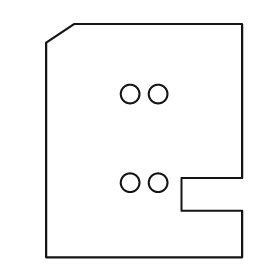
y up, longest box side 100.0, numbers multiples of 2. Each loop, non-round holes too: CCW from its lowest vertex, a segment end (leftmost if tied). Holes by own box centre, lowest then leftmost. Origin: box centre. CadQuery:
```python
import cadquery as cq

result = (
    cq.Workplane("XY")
    .moveTo(-42.0, -50.0)
    .lineTo(42.0, -50.0)
    .lineTo(42.0, -30.0)
    .lineTo(16.0, -30.0)
    .lineTo(16.0, -16.0)
    .lineTo(42.0, -16.0)
    .lineTo(42.0, 50.0)
    .lineTo(-30.0, 50.0)
    .lineTo(-42.0, 42.0)
    .close()
    .moveTo(-6.0, -18.0)
    .circle(4.0)
    .moveTo(6.0, -18.0)
    .circle(4.0)
    .moveTo(-6.0, 20.0)
    .circle(4.0)
    .moveTo(6.0, 20.0)
    .circle(4.0)
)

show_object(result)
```